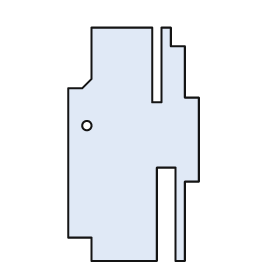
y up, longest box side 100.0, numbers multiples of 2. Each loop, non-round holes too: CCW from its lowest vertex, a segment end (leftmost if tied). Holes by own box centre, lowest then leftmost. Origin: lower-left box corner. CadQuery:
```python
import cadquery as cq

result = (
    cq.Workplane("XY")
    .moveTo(10.0, 0.0)
    .lineTo(38.0, 0.0)
    .lineTo(38.0, 40.0)
    .lineTo(46.0, 40.0)
    .lineTo(46.0, 0.0)
    .lineTo(50.0, 0.0)
    .lineTo(50.0, 34.0)
    .lineTo(56.0, 34.0)
    .lineTo(56.0, 70.0)
    .lineTo(50.0, 70.0)
    .lineTo(50.0, 92.0)
    .lineTo(44.0, 92.0)
    .lineTo(44.0, 100.0)
    .lineTo(40.0, 100.0)
    .lineTo(40.0, 68.0)
    .lineTo(36.0, 68.0)
    .lineTo(36.0, 100.0)
    .lineTo(10.0, 100.0)
    .lineTo(10.0, 78.0)
    .lineTo(6.0, 74.0)
    .lineTo(0.0, 74.0)
    .lineTo(0.0, 10.0)
    .lineTo(10.0, 10.0)
    .close()
    .moveTo(8.0, 58.0)
    .circle(2.0)
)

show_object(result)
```